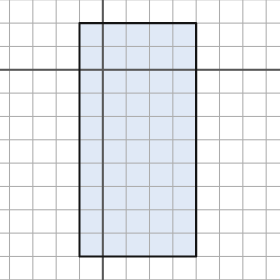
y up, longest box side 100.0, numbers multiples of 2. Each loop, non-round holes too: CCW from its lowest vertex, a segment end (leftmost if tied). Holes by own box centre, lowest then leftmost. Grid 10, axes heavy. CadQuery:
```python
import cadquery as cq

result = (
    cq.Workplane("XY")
    .moveTo(-10.0, -80.0)
    .lineTo(40.0, -80.0)
    .lineTo(40.0, 20.0)
    .lineTo(-10.0, 20.0)
    .close()
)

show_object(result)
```